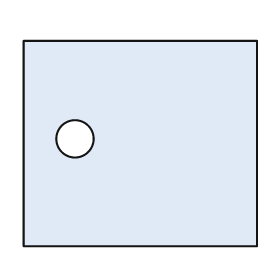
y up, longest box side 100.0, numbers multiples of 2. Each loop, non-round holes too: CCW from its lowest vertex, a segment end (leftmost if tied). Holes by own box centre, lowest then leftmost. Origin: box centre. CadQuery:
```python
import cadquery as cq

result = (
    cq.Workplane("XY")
    .moveTo(-50.0, -44.0)
    .lineTo(50.0, -44.0)
    .lineTo(50.0, 44.0)
    .lineTo(-50.0, 44.0)
    .close()
    .moveTo(-28.0, 2.0)
    .circle(8.0)
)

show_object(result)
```